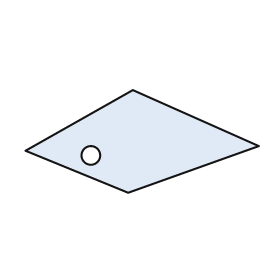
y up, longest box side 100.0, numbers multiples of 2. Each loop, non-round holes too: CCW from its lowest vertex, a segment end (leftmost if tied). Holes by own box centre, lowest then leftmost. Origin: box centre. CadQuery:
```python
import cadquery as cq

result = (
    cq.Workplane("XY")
    .moveTo(-6.0, -22.0)
    .lineTo(50.0, -2.0)
    .lineTo(-4.0, 22.0)
    .lineTo(-50.0, -4.0)
    .close()
    .moveTo(-22.0, -6.0)
    .circle(4.0)
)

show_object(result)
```